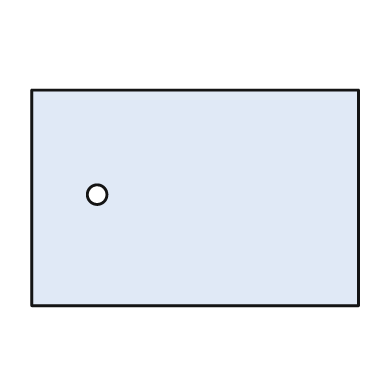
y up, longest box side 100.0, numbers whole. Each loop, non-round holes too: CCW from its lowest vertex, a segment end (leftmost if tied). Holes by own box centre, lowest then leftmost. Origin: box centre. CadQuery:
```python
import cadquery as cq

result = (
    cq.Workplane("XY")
    .moveTo(-50.0, -33.0)
    .lineTo(50.0, -33.0)
    .lineTo(50.0, 33.0)
    .lineTo(-50.0, 33.0)
    .close()
    .moveTo(-30.0, 1.0)
    .circle(3.0)
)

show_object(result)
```